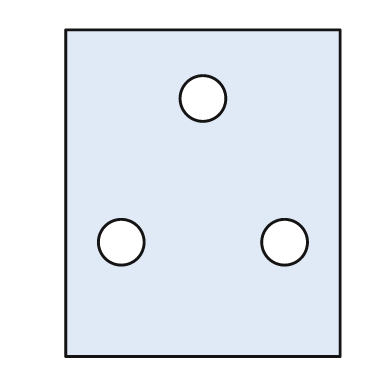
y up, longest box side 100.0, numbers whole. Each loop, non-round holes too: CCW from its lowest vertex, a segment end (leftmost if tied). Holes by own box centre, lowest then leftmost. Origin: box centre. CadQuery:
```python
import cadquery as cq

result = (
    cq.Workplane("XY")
    .moveTo(-42.0, -50.0)
    .lineTo(42.0, -50.0)
    .lineTo(42.0, 50.0)
    .lineTo(-42.0, 50.0)
    .close()
    .moveTo(-25.0, -15.0)
    .circle(7.0)
    .moveTo(25.0, -15.0)
    .circle(7.0)
    .moveTo(0.0, 29.0)
    .circle(7.0)
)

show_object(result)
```